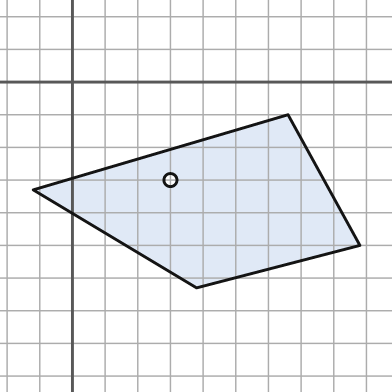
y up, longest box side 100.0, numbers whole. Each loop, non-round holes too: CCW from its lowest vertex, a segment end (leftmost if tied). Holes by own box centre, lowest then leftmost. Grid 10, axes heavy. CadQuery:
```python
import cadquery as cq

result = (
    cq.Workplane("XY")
    .moveTo(38.0, -63.0)
    .lineTo(88.0, -50.0)
    .lineTo(66.0, -10.0)
    .lineTo(-12.0, -33.0)
    .close()
    .moveTo(30.0, -30.0)
    .circle(2.0)
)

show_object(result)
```